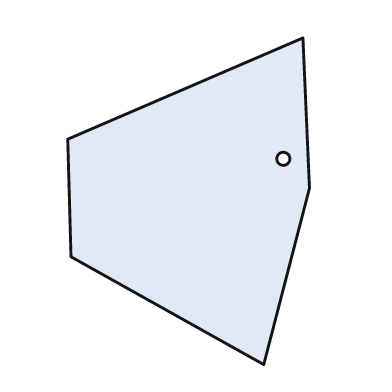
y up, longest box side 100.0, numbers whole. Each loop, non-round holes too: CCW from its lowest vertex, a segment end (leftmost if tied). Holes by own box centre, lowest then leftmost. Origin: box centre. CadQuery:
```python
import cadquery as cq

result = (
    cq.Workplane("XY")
    .moveTo(23.0, -50.0)
    .lineTo(37.0, 4.0)
    .lineTo(35.0, 50.0)
    .lineTo(-37.0, 19.0)
    .lineTo(-36.0, -17.0)
    .close()
    .moveTo(29.0, 13.0)
    .circle(2.0)
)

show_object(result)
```